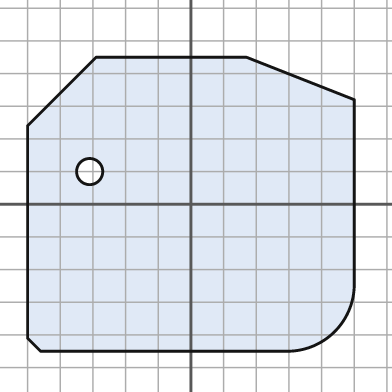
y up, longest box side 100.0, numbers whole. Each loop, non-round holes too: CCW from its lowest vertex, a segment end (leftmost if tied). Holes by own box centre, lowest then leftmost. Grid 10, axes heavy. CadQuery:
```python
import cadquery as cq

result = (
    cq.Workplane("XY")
    .moveTo(-46.0, -45.0)
    .lineTo(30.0, -45.0)
    .threePointArc((44.0, -39.0), (50.0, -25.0))
    .lineTo(50.0, 32.0)
    .lineTo(17.0, 45.0)
    .lineTo(-29.0, 45.0)
    .lineTo(-50.0, 24.0)
    .lineTo(-50.0, -41.0)
    .close()
    .moveTo(-31.0, 10.0)
    .circle(4.0)
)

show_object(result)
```